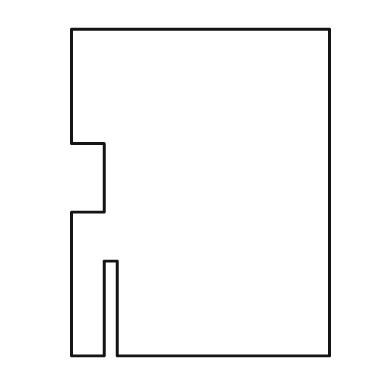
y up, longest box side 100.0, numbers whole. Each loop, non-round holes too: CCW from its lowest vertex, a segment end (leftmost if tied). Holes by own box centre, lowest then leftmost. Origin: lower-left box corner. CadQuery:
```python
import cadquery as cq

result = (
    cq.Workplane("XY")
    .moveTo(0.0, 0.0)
    .lineTo(10.0, 0.0)
    .lineTo(10.0, 29.0)
    .lineTo(14.0, 29.0)
    .lineTo(14.0, 0.0)
    .lineTo(79.0, 0.0)
    .lineTo(79.0, 100.0)
    .lineTo(0.0, 100.0)
    .lineTo(0.0, 65.0)
    .lineTo(10.0, 65.0)
    .lineTo(10.0, 44.0)
    .lineTo(0.0, 44.0)
    .close()
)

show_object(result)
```